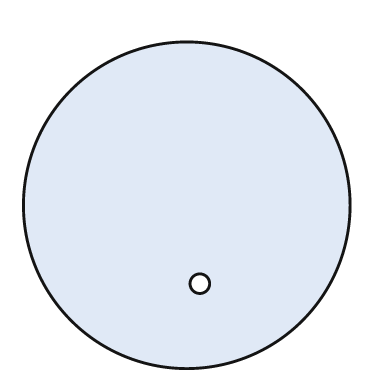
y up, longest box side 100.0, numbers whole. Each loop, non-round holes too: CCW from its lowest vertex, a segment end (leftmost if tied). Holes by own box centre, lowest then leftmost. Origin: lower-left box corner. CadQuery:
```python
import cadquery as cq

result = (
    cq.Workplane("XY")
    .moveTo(50.0, 50.0)
    .circle(50.0)
    .moveTo(54.0, 26.0)
    .circle(3.0)
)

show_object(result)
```